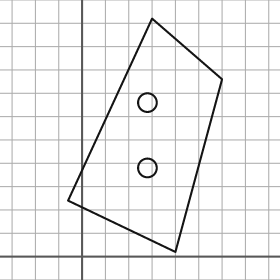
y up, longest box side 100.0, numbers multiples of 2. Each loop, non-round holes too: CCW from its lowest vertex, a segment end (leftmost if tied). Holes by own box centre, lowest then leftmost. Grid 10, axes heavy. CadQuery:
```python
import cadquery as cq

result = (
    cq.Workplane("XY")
    .moveTo(40.0, 2.0)
    .lineTo(60.0, 76.0)
    .lineTo(30.0, 102.0)
    .lineTo(-6.0, 24.0)
    .close()
    .moveTo(28.0, 38.0)
    .circle(4.0)
    .moveTo(28.0, 66.0)
    .circle(4.0)
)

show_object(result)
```